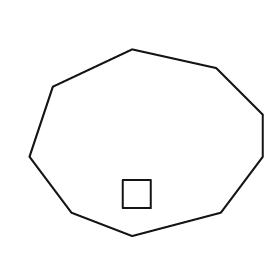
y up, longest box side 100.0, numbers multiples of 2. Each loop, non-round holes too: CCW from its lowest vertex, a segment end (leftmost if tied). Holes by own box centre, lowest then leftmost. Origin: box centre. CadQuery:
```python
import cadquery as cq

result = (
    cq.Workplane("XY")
    .moveTo(-6.0, -40.0)
    .lineTo(32.0, -30.0)
    .lineTo(50.0, -6.0)
    .lineTo(50.0, 12.0)
    .lineTo(30.0, 32.0)
    .lineTo(-6.0, 40.0)
    .lineTo(-40.0, 24.0)
    .lineTo(-50.0, -6.0)
    .lineTo(-32.0, -30.0)
    .close()
    .moveTo(-10.0, -28.0)
    .lineTo(2.0, -28.0)
    .lineTo(2.0, -16.0)
    .lineTo(-10.0, -16.0)
    .close()
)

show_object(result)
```